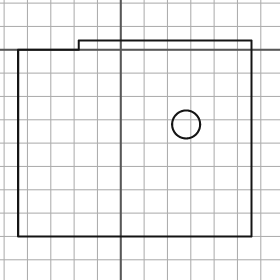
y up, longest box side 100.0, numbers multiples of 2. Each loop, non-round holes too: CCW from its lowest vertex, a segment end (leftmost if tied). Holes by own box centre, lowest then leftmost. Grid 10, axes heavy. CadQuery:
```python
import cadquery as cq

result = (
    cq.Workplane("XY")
    .moveTo(-44.0, -80.0)
    .lineTo(56.0, -80.0)
    .lineTo(56.0, 4.0)
    .lineTo(-18.0, 4.0)
    .lineTo(-18.0, 0.0)
    .lineTo(-44.0, 0.0)
    .close()
    .moveTo(28.0, -32.0)
    .circle(6.0)
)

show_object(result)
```